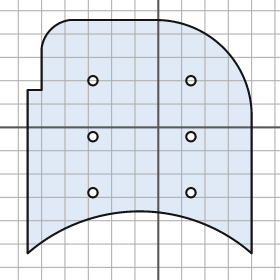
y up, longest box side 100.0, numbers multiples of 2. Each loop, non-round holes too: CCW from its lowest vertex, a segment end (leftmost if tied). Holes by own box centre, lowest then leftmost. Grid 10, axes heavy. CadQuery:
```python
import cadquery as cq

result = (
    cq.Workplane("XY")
    .moveTo(-56.0, -54.0)
    .threePointArc((-8.0, -36.0), (40.0, -54.0))
    .lineTo(40.0, 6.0)
    .threePointArc((28.0, 34.0), (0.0, 46.0))
    .lineTo(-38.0, 46.0)
    .threePointArc((-46.0, 42.0), (-50.0, 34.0))
    .lineTo(-50.0, 16.0)
    .lineTo(-56.0, 16.0)
    .close()
    .moveTo(-28.0, -28.0)
    .circle(2.0)
    .moveTo(14.0, -28.0)
    .circle(2.0)
    .moveTo(-28.0, -4.0)
    .circle(2.0)
    .moveTo(14.0, -4.0)
    .circle(2.0)
    .moveTo(-28.0, 20.0)
    .circle(2.0)
    .moveTo(14.0, 20.0)
    .circle(2.0)
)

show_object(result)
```